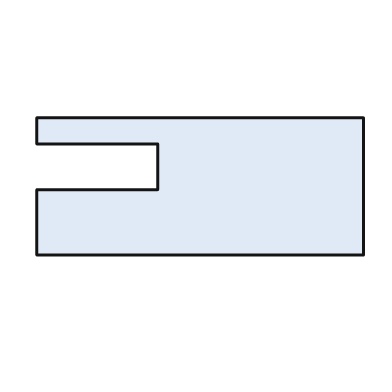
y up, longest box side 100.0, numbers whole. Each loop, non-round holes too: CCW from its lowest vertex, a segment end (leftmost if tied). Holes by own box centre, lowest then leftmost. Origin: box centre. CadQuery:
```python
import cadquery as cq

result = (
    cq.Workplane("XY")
    .moveTo(-50.0, -21.0)
    .lineTo(50.0, -21.0)
    .lineTo(50.0, 21.0)
    .lineTo(-50.0, 21.0)
    .lineTo(-50.0, 13.0)
    .lineTo(-13.0, 13.0)
    .lineTo(-13.0, -1.0)
    .lineTo(-50.0, -1.0)
    .close()
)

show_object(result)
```